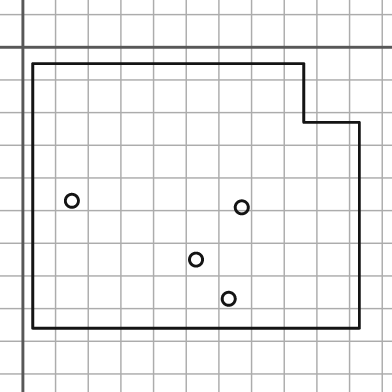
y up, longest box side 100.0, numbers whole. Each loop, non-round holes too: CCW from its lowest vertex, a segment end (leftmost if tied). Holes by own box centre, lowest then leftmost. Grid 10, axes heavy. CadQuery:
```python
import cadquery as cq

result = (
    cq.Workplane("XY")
    .moveTo(3.0, -86.0)
    .lineTo(103.0, -86.0)
    .lineTo(103.0, -23.0)
    .lineTo(86.0, -23.0)
    .lineTo(86.0, -5.0)
    .lineTo(3.0, -5.0)
    .close()
    .moveTo(63.0, -77.0)
    .circle(2.0)
    .moveTo(53.0, -65.0)
    .circle(2.0)
    .moveTo(67.0, -49.0)
    .circle(2.0)
    .moveTo(15.0, -47.0)
    .circle(2.0)
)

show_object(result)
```